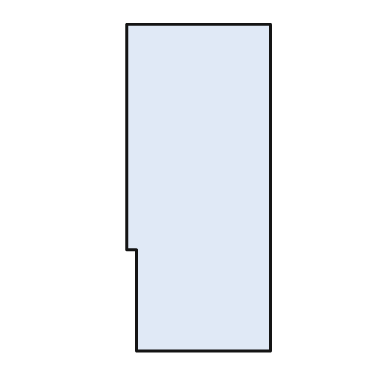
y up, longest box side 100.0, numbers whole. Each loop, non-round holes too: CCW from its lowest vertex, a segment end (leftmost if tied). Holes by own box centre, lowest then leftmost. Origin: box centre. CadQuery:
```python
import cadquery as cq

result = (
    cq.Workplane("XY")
    .moveTo(-19.0, -50.0)
    .lineTo(22.0, -50.0)
    .lineTo(22.0, 50.0)
    .lineTo(-22.0, 50.0)
    .lineTo(-22.0, -19.0)
    .lineTo(-19.0, -19.0)
    .close()
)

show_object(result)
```